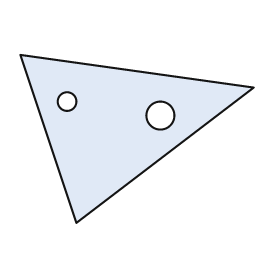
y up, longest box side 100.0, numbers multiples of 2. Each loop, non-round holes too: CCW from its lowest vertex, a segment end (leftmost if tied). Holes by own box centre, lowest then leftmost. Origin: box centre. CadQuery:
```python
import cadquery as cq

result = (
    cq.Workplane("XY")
    .moveTo(-26.0, -36.0)
    .lineTo(50.0, 22.0)
    .lineTo(-50.0, 36.0)
    .close()
    .moveTo(10.0, 10.0)
    .circle(6.0)
    .moveTo(-30.0, 16.0)
    .circle(4.0)
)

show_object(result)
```